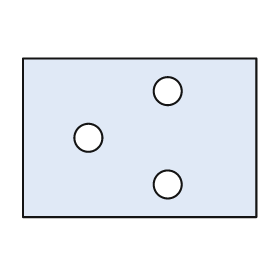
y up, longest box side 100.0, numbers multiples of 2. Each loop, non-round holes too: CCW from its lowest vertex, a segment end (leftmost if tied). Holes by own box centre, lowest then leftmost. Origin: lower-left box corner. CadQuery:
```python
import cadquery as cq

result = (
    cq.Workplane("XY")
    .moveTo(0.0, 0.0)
    .lineTo(100.0, 0.0)
    .lineTo(100.0, 68.0)
    .lineTo(0.0, 68.0)
    .close()
    .moveTo(62.0, 14.0)
    .circle(6.0)
    .moveTo(28.0, 34.0)
    .circle(6.0)
    .moveTo(62.0, 54.0)
    .circle(6.0)
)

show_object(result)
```